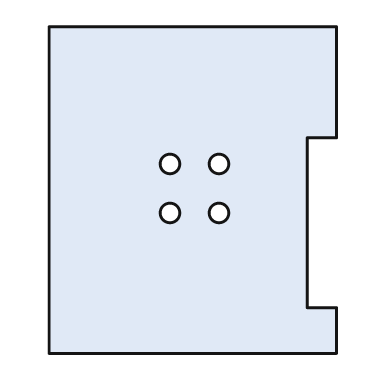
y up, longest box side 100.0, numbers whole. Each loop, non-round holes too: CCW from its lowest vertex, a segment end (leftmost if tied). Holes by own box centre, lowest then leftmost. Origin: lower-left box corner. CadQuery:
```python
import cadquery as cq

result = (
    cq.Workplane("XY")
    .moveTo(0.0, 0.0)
    .lineTo(88.0, 0.0)
    .lineTo(88.0, 14.0)
    .lineTo(79.0, 14.0)
    .lineTo(79.0, 66.0)
    .lineTo(88.0, 66.0)
    .lineTo(88.0, 100.0)
    .lineTo(0.0, 100.0)
    .close()
    .moveTo(37.0, 43.0)
    .circle(3.0)
    .moveTo(52.0, 43.0)
    .circle(3.0)
    .moveTo(37.0, 58.0)
    .circle(3.0)
    .moveTo(52.0, 58.0)
    .circle(3.0)
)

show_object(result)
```